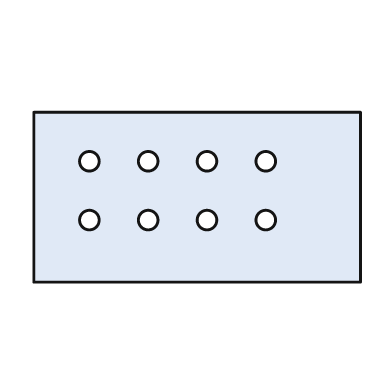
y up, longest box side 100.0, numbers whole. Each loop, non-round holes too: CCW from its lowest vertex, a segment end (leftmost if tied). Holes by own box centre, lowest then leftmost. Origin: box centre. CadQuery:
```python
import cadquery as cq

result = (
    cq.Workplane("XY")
    .moveTo(-50.0, -26.0)
    .lineTo(50.0, -26.0)
    .lineTo(50.0, 26.0)
    .lineTo(-50.0, 26.0)
    .close()
    .moveTo(-33.0, -7.0)
    .circle(3.0)
    .moveTo(-15.0, -7.0)
    .circle(3.0)
    .moveTo(3.0, -7.0)
    .circle(3.0)
    .moveTo(21.0, -7.0)
    .circle(3.0)
    .moveTo(-33.0, 11.0)
    .circle(3.0)
    .moveTo(-15.0, 11.0)
    .circle(3.0)
    .moveTo(3.0, 11.0)
    .circle(3.0)
    .moveTo(21.0, 11.0)
    .circle(3.0)
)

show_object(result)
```